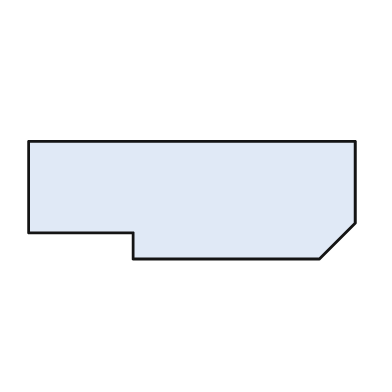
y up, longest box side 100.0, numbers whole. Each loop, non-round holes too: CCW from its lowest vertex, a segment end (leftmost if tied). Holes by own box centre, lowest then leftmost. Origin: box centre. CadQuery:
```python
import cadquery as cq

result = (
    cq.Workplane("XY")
    .moveTo(-18.0, -18.0)
    .lineTo(39.0, -18.0)
    .lineTo(50.0, -7.0)
    .lineTo(50.0, 18.0)
    .lineTo(-50.0, 18.0)
    .lineTo(-50.0, -10.0)
    .lineTo(-18.0, -10.0)
    .close()
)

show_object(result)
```